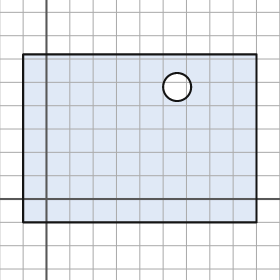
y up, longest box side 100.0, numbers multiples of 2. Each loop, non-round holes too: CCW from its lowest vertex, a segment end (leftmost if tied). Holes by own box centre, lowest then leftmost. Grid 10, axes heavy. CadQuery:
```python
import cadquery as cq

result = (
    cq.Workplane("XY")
    .moveTo(-10.0, -10.0)
    .lineTo(90.0, -10.0)
    .lineTo(90.0, 62.0)
    .lineTo(-10.0, 62.0)
    .close()
    .moveTo(56.0, 48.0)
    .circle(6.0)
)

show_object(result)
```